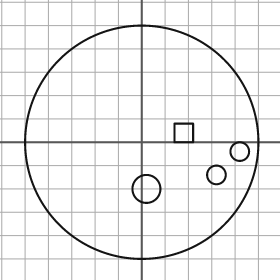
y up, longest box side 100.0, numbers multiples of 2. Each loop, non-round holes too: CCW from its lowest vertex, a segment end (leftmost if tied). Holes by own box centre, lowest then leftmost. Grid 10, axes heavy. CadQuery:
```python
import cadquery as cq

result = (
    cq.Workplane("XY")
    .moveTo(0.0, 0.0)
    .circle(50.0)
    .moveTo(2.0, -20.0)
    .circle(6.0)
    .moveTo(32.0, -14.0)
    .circle(4.0)
    .moveTo(42.0, -4.0)
    .circle(4.0)
    .moveTo(14.0, 0.0)
    .lineTo(22.0, 0.0)
    .lineTo(22.0, 8.0)
    .lineTo(14.0, 8.0)
    .close()
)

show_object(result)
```